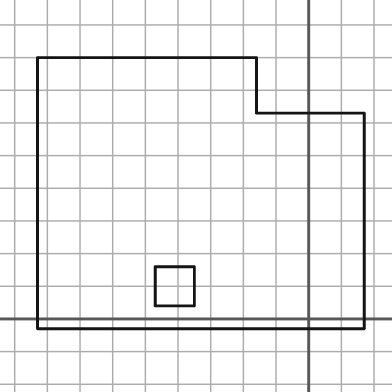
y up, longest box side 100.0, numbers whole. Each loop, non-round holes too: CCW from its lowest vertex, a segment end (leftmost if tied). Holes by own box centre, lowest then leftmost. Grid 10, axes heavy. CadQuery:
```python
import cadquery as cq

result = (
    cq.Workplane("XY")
    .moveTo(-83.0, -3.0)
    .lineTo(17.0, -3.0)
    .lineTo(17.0, 63.0)
    .lineTo(-16.0, 63.0)
    .lineTo(-16.0, 80.0)
    .lineTo(-83.0, 80.0)
    .close()
    .moveTo(-47.0, 4.0)
    .lineTo(-35.0, 4.0)
    .lineTo(-35.0, 16.0)
    .lineTo(-47.0, 16.0)
    .close()
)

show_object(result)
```